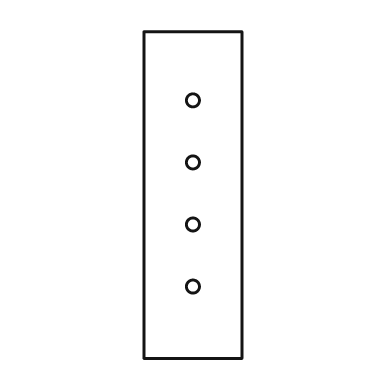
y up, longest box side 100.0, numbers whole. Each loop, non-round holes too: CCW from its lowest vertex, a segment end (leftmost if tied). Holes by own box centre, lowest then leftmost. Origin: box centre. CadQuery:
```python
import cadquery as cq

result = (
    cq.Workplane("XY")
    .moveTo(-15.0, -50.0)
    .lineTo(15.0, -50.0)
    .lineTo(15.0, 50.0)
    .lineTo(-15.0, 50.0)
    .close()
    .moveTo(0.0, -28.0)
    .circle(2.0)
    .moveTo(0.0, -9.0)
    .circle(2.0)
    .moveTo(0.0, 10.0)
    .circle(2.0)
    .moveTo(0.0, 29.0)
    .circle(2.0)
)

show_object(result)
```